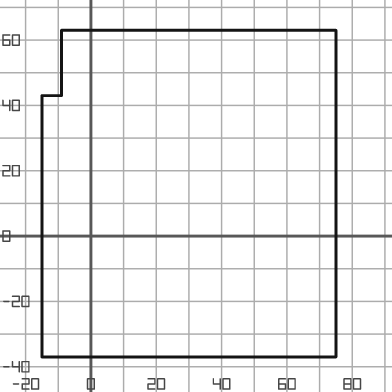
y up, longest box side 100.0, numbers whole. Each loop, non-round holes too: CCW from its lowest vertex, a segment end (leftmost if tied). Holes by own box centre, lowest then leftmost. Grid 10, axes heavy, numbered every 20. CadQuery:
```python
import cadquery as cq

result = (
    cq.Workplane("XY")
    .moveTo(-15.0, -37.0)
    .lineTo(75.0, -37.0)
    .lineTo(75.0, 63.0)
    .lineTo(-9.0, 63.0)
    .lineTo(-9.0, 43.0)
    .lineTo(-15.0, 43.0)
    .close()
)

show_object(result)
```